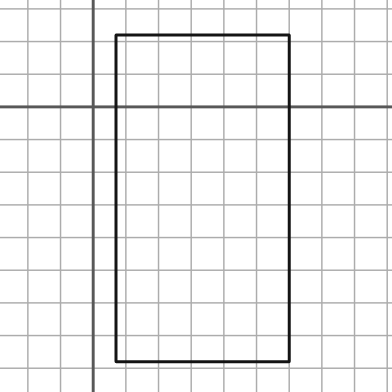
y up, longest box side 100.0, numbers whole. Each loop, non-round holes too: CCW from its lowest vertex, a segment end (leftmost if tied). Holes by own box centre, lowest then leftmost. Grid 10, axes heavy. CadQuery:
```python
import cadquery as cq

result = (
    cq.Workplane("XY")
    .moveTo(7.0, -78.0)
    .lineTo(60.0, -78.0)
    .lineTo(60.0, 22.0)
    .lineTo(7.0, 22.0)
    .close()
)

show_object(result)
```